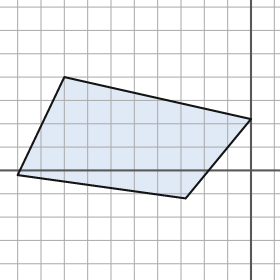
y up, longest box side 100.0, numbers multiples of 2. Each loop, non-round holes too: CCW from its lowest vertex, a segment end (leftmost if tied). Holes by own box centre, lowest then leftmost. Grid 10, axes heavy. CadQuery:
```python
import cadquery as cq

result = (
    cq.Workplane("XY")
    .moveTo(-28.0, -12.0)
    .lineTo(0.0, 22.0)
    .lineTo(-80.0, 40.0)
    .lineTo(-100.0, -2.0)
    .close()
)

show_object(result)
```